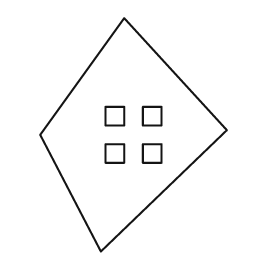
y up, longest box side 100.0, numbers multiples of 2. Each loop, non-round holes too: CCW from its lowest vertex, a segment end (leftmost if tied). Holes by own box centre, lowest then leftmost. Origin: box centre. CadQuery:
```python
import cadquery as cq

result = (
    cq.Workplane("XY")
    .moveTo(-14.0, -50.0)
    .lineTo(40.0, 2.0)
    .lineTo(-4.0, 50.0)
    .lineTo(-40.0, 0.0)
    .close()
    .moveTo(-12.0, -12.0)
    .lineTo(-4.0, -12.0)
    .lineTo(-4.0, -4.0)
    .lineTo(-12.0, -4.0)
    .close()
    .moveTo(4.0, -12.0)
    .lineTo(12.0, -12.0)
    .lineTo(12.0, -4.0)
    .lineTo(4.0, -4.0)
    .close()
    .moveTo(-12.0, 4.0)
    .lineTo(-4.0, 4.0)
    .lineTo(-4.0, 12.0)
    .lineTo(-12.0, 12.0)
    .close()
    .moveTo(4.0, 4.0)
    .lineTo(12.0, 4.0)
    .lineTo(12.0, 12.0)
    .lineTo(4.0, 12.0)
    .close()
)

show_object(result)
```